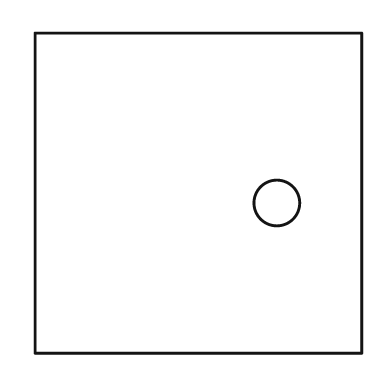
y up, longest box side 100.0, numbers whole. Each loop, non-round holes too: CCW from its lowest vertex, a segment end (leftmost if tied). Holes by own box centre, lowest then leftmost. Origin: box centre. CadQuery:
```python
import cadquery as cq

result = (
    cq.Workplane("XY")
    .moveTo(-50.0, -49.0)
    .lineTo(50.0, -49.0)
    .lineTo(50.0, 49.0)
    .lineTo(-50.0, 49.0)
    .close()
    .moveTo(24.0, -3.0)
    .circle(7.0)
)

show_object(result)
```